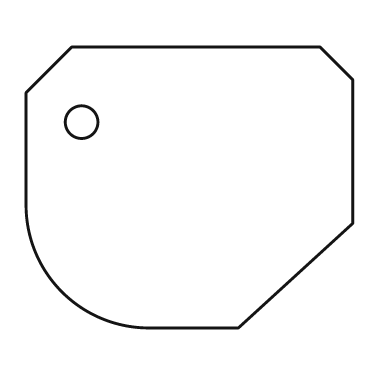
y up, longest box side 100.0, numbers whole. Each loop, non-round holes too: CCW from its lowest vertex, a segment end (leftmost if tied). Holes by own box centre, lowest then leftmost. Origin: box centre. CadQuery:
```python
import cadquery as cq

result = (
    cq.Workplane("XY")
    .moveTo(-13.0, -43.0)
    .lineTo(15.0, -43.0)
    .lineTo(50.0, -11.0)
    .lineTo(50.0, 33.0)
    .lineTo(40.0, 43.0)
    .lineTo(-36.0, 43.0)
    .lineTo(-50.0, 29.0)
    .lineTo(-50.0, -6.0)
    .threePointArc((-39.0, -32.0), (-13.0, -43.0))
    .close()
    .moveTo(-33.0, 20.0)
    .circle(5.0)
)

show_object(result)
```